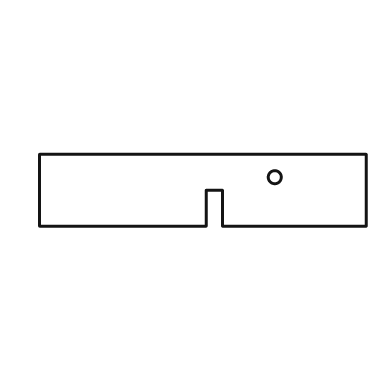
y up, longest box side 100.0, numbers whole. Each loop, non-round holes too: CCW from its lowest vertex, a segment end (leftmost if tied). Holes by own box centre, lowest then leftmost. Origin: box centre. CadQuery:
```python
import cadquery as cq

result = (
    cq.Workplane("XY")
    .moveTo(-50.0, -11.0)
    .lineTo(1.0, -11.0)
    .lineTo(1.0, 0.0)
    .lineTo(6.0, 0.0)
    .lineTo(6.0, -11.0)
    .lineTo(50.0, -11.0)
    .lineTo(50.0, 11.0)
    .lineTo(-50.0, 11.0)
    .close()
    .moveTo(22.0, 4.0)
    .circle(2.0)
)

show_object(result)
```